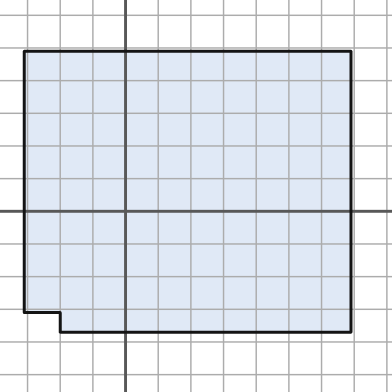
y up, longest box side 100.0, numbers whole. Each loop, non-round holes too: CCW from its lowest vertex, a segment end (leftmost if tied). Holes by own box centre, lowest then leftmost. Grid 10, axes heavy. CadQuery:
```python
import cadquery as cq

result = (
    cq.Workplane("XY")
    .moveTo(-20.0, -37.0)
    .lineTo(69.0, -37.0)
    .lineTo(69.0, 49.0)
    .lineTo(-31.0, 49.0)
    .lineTo(-31.0, -31.0)
    .lineTo(-20.0, -31.0)
    .close()
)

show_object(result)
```